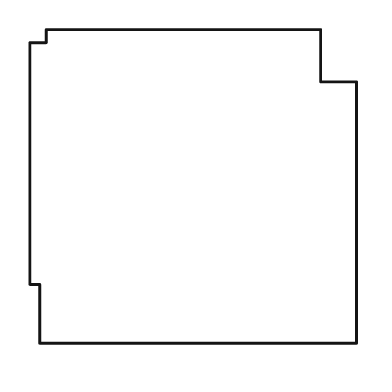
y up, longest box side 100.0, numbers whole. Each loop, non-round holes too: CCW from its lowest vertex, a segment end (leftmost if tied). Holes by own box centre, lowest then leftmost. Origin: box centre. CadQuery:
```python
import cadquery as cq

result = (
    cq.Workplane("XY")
    .moveTo(-47.0, -48.0)
    .lineTo(50.0, -48.0)
    .lineTo(50.0, 32.0)
    .lineTo(39.0, 32.0)
    .lineTo(39.0, 48.0)
    .lineTo(-45.0, 48.0)
    .lineTo(-45.0, 44.0)
    .lineTo(-50.0, 44.0)
    .lineTo(-50.0, -30.0)
    .lineTo(-47.0, -30.0)
    .close()
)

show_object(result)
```